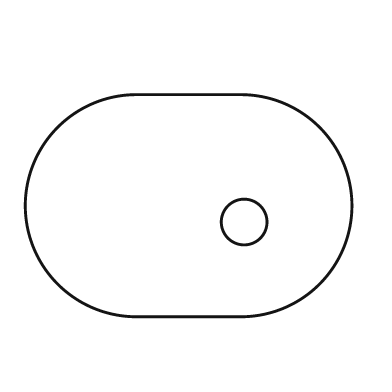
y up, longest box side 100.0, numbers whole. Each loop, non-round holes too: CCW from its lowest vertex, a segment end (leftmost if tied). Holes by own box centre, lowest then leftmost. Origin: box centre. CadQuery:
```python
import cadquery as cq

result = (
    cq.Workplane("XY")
    .moveTo(-16.0, -34.0)
    .lineTo(16.0, -34.0)
    .threePointArc((50.0, 0.0), (16.0, 34.0))
    .lineTo(-16.0, 34.0)
    .threePointArc((-50.0, 0.0), (-16.0, -34.0))
    .close()
    .moveTo(17.0, -5.0)
    .circle(7.0)
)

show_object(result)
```